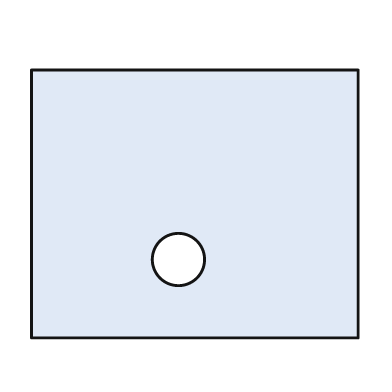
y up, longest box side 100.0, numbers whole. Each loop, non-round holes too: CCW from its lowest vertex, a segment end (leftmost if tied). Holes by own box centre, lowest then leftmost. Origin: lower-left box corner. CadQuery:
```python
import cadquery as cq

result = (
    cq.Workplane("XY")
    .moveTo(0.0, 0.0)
    .lineTo(100.0, 0.0)
    .lineTo(100.0, 82.0)
    .lineTo(0.0, 82.0)
    .close()
    .moveTo(45.0, 24.0)
    .circle(8.0)
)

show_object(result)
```